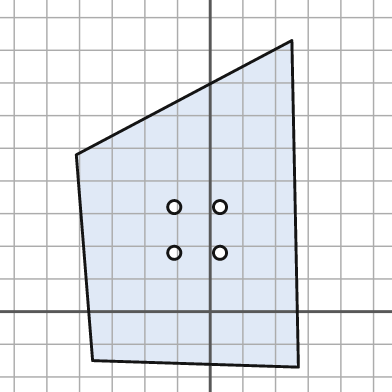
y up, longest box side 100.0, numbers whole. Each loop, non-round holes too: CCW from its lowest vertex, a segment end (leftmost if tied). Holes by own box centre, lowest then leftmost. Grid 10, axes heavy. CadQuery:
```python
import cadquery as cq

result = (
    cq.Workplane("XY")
    .moveTo(27.0, -17.0)
    .lineTo(25.0, 83.0)
    .lineTo(-41.0, 48.0)
    .lineTo(-36.0, -15.0)
    .close()
    .moveTo(-11.0, 18.0)
    .circle(2.0)
    .moveTo(3.0, 18.0)
    .circle(2.0)
    .moveTo(-11.0, 32.0)
    .circle(2.0)
    .moveTo(3.0, 32.0)
    .circle(2.0)
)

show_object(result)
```